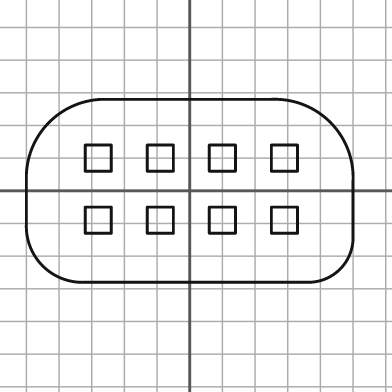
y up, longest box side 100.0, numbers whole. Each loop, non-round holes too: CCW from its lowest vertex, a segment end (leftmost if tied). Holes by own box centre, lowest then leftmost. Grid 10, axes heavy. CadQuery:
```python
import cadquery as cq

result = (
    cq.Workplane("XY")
    .moveTo(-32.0, -28.0)
    .lineTo(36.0, -28.0)
    .threePointArc((46.0, -24.0), (50.0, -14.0))
    .lineTo(50.0, 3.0)
    .threePointArc((43.0, 21.0), (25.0, 28.0))
    .lineTo(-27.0, 28.0)
    .threePointArc((-43.0, 21.0), (-50.0, 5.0))
    .lineTo(-50.0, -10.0)
    .threePointArc((-45.0, -23.0), (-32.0, -28.0))
    .close()
    .moveTo(-32.0, -13.0)
    .lineTo(-24.0, -13.0)
    .lineTo(-24.0, -5.0)
    .lineTo(-32.0, -5.0)
    .close()
    .moveTo(-13.0, -13.0)
    .lineTo(-5.0, -13.0)
    .lineTo(-5.0, -5.0)
    .lineTo(-13.0, -5.0)
    .close()
    .moveTo(6.0, -13.0)
    .lineTo(14.0, -13.0)
    .lineTo(14.0, -5.0)
    .lineTo(6.0, -5.0)
    .close()
    .moveTo(25.0, -13.0)
    .lineTo(33.0, -13.0)
    .lineTo(33.0, -5.0)
    .lineTo(25.0, -5.0)
    .close()
    .moveTo(-32.0, 6.0)
    .lineTo(-24.0, 6.0)
    .lineTo(-24.0, 14.0)
    .lineTo(-32.0, 14.0)
    .close()
    .moveTo(-13.0, 6.0)
    .lineTo(-5.0, 6.0)
    .lineTo(-5.0, 14.0)
    .lineTo(-13.0, 14.0)
    .close()
    .moveTo(6.0, 6.0)
    .lineTo(14.0, 6.0)
    .lineTo(14.0, 14.0)
    .lineTo(6.0, 14.0)
    .close()
    .moveTo(25.0, 6.0)
    .lineTo(33.0, 6.0)
    .lineTo(33.0, 14.0)
    .lineTo(25.0, 14.0)
    .close()
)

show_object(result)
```